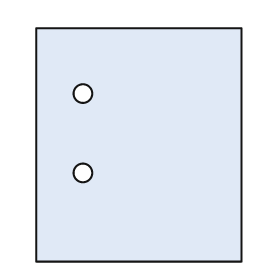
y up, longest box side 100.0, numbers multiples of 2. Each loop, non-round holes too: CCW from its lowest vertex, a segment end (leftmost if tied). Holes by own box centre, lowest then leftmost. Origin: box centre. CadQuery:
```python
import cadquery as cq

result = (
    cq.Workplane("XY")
    .moveTo(-44.0, -50.0)
    .lineTo(44.0, -50.0)
    .lineTo(44.0, 50.0)
    .lineTo(-44.0, 50.0)
    .close()
    .moveTo(-24.0, -12.0)
    .circle(4.0)
    .moveTo(-24.0, 22.0)
    .circle(4.0)
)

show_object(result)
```